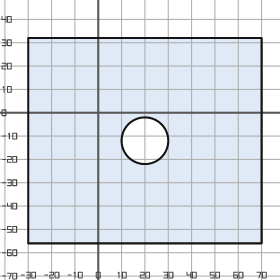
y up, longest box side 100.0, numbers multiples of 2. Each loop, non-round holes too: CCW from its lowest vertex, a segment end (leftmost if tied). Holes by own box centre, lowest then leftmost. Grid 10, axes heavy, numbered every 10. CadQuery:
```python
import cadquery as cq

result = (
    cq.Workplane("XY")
    .moveTo(-30.0, -56.0)
    .lineTo(70.0, -56.0)
    .lineTo(70.0, 32.0)
    .lineTo(-30.0, 32.0)
    .close()
    .moveTo(20.0, -12.0)
    .circle(10.0)
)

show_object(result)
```